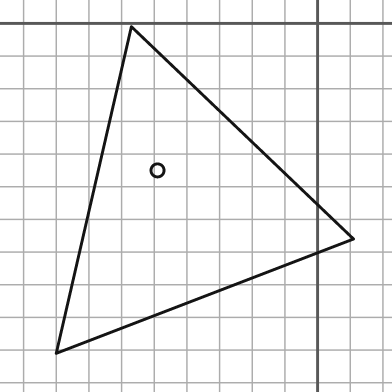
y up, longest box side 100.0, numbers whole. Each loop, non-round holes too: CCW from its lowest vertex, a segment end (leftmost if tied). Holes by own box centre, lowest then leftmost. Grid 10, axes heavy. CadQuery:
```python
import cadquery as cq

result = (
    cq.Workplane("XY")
    .moveTo(-80.0, -101.0)
    .lineTo(11.0, -66.0)
    .lineTo(-57.0, -1.0)
    .close()
    .moveTo(-49.0, -45.0)
    .circle(2.0)
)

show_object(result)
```